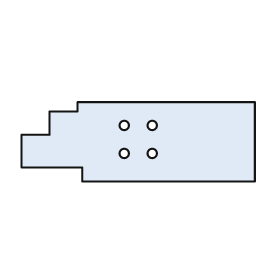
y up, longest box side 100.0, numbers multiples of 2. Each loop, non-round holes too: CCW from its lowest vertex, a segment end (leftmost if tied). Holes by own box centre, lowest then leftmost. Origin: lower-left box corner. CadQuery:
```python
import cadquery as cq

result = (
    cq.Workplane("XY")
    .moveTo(26.0, 0.0)
    .lineTo(100.0, 0.0)
    .lineTo(100.0, 34.0)
    .lineTo(24.0, 34.0)
    .lineTo(24.0, 30.0)
    .lineTo(12.0, 30.0)
    .lineTo(12.0, 20.0)
    .lineTo(0.0, 20.0)
    .lineTo(0.0, 6.0)
    .lineTo(26.0, 6.0)
    .close()
    .moveTo(44.0, 12.0)
    .circle(2.0)
    .moveTo(56.0, 12.0)
    .circle(2.0)
    .moveTo(44.0, 24.0)
    .circle(2.0)
    .moveTo(56.0, 24.0)
    .circle(2.0)
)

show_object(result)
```